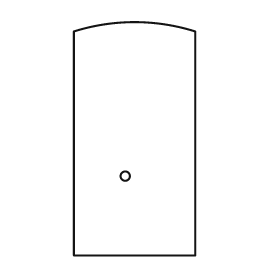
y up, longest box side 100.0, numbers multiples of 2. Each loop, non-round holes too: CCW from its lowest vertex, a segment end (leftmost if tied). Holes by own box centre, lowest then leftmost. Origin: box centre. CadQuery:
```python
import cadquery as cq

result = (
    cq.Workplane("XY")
    .moveTo(-26.0, -50.0)
    .lineTo(26.0, -50.0)
    .lineTo(26.0, 46.0)
    .threePointArc((0.0, 50.0), (-26.0, 46.0))
    .close()
    .moveTo(-4.0, -16.0)
    .circle(2.0)
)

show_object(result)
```